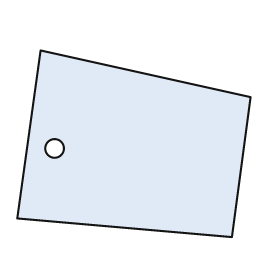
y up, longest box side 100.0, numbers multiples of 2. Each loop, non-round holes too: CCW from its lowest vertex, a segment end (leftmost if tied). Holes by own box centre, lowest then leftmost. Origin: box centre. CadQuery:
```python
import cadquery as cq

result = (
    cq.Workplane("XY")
    .moveTo(42.0, -40.0)
    .lineTo(50.0, 20.0)
    .lineTo(-40.0, 40.0)
    .lineTo(-50.0, -32.0)
    .close()
    .moveTo(-34.0, -2.0)
    .circle(4.0)
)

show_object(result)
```